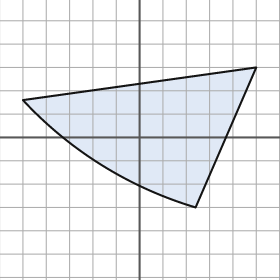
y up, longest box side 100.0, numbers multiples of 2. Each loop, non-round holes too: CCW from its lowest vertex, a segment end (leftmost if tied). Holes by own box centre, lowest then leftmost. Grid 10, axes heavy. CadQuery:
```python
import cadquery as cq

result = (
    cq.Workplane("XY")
    .moveTo(24.0, -30.0)
    .lineTo(50.0, 30.0)
    .lineTo(-50.0, 16.0)
    .threePointArc((-16.0, -12.0), (24.0, -30.0))
    .close()
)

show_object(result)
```